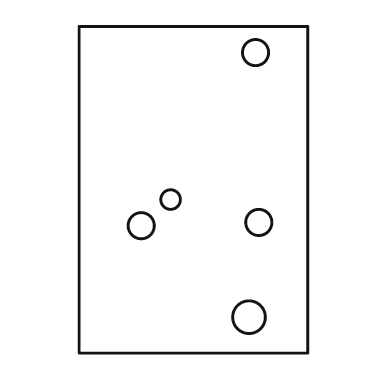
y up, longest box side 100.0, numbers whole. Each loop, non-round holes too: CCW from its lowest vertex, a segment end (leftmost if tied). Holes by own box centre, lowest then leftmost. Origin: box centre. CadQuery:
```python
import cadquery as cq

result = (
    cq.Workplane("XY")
    .moveTo(-35.0, -50.0)
    .lineTo(35.0, -50.0)
    .lineTo(35.0, 50.0)
    .lineTo(-35.0, 50.0)
    .close()
    .moveTo(17.0, -39.0)
    .circle(5.0)
    .moveTo(-16.0, -11.0)
    .circle(4.0)
    .moveTo(20.0, -10.0)
    .circle(4.0)
    .moveTo(-7.0, -3.0)
    .circle(3.0)
    .moveTo(19.0, 42.0)
    .circle(4.0)
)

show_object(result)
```